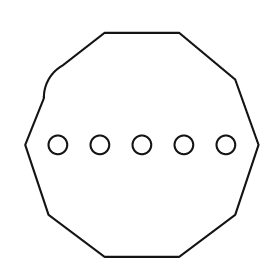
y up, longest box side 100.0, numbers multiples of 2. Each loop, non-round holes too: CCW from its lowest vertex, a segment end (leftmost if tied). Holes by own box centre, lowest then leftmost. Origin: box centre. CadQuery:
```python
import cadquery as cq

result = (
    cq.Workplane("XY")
    .moveTo(-16.0, -48.0)
    .lineTo(16.0, -48.0)
    .lineTo(40.0, -30.0)
    .lineTo(50.0, 0.0)
    .lineTo(40.0, 28.0)
    .lineTo(16.0, 48.0)
    .lineTo(-16.0, 48.0)
    .lineTo(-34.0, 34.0)
    .threePointArc((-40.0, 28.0), (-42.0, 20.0))
    .lineTo(-50.0, 0.0)
    .lineTo(-40.0, -30.0)
    .close()
    .moveTo(-36.0, 0.0)
    .circle(4.0)
    .moveTo(-18.0, 0.0)
    .circle(4.0)
    .moveTo(0.0, 0.0)
    .circle(4.0)
    .moveTo(18.0, 0.0)
    .circle(4.0)
    .moveTo(36.0, 0.0)
    .circle(4.0)
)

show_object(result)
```